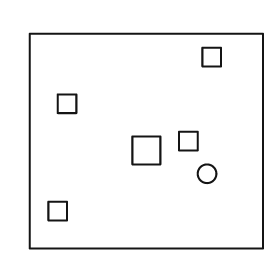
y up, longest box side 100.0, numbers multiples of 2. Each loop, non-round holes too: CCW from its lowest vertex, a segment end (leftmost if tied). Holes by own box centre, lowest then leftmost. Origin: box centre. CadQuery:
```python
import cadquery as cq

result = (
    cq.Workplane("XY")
    .moveTo(-50.0, -46.0)
    .lineTo(50.0, -46.0)
    .lineTo(50.0, 46.0)
    .lineTo(-50.0, 46.0)
    .close()
    .moveTo(-42.0, -34.0)
    .lineTo(-34.0, -34.0)
    .lineTo(-34.0, -26.0)
    .lineTo(-42.0, -26.0)
    .close()
    .moveTo(26.0, -14.0)
    .circle(4.0)
    .moveTo(-6.0, -10.0)
    .lineTo(6.0, -10.0)
    .lineTo(6.0, 2.0)
    .lineTo(-6.0, 2.0)
    .close()
    .moveTo(14.0, -4.0)
    .lineTo(22.0, -4.0)
    .lineTo(22.0, 4.0)
    .lineTo(14.0, 4.0)
    .close()
    .moveTo(-38.0, 12.0)
    .lineTo(-30.0, 12.0)
    .lineTo(-30.0, 20.0)
    .lineTo(-38.0, 20.0)
    .close()
    .moveTo(24.0, 32.0)
    .lineTo(32.0, 32.0)
    .lineTo(32.0, 40.0)
    .lineTo(24.0, 40.0)
    .close()
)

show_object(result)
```